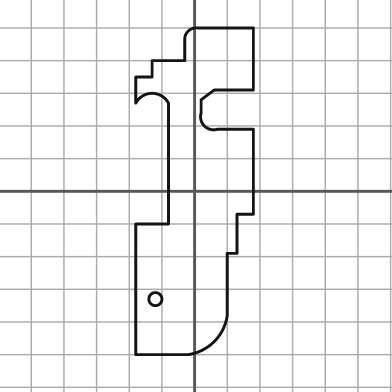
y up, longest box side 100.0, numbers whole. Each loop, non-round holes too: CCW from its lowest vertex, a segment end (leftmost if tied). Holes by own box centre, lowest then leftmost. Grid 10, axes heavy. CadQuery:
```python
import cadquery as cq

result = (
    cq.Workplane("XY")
    .moveTo(-18.0, -50.0)
    .lineTo(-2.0, -50.0)
    .threePointArc((6.0, -46.0), (10.0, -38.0))
    .lineTo(10.0, -19.0)
    .lineTo(13.0, -19.0)
    .lineTo(13.0, -7.0)
    .lineTo(18.0, -7.0)
    .lineTo(18.0, 19.0)
    .lineTo(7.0, 19.0)
    .threePointArc((3.0, 20.0), (2.0, 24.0))
    .lineTo(2.0, 28.0)
    .lineTo(6.0, 31.0)
    .lineTo(18.0, 31.0)
    .lineTo(18.0, 50.0)
    .lineTo(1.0, 50.0)
    .threePointArc((-2.0, 49.0), (-3.0, 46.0))
    .lineTo(-3.0, 40.0)
    .lineTo(-13.0, 40.0)
    .lineTo(-13.0, 35.0)
    .lineTo(-18.0, 35.0)
    .lineTo(-18.0, 27.0)
    .threePointArc((-13.0, 30.0), (-8.0, 27.0))
    .lineTo(-8.0, -10.0)
    .lineTo(-18.0, -10.0)
    .close()
    .moveTo(-12.0, -33.0)
    .circle(2.0)
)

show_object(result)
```